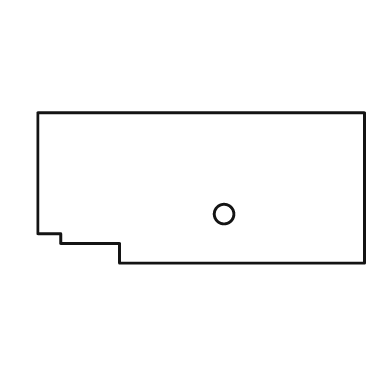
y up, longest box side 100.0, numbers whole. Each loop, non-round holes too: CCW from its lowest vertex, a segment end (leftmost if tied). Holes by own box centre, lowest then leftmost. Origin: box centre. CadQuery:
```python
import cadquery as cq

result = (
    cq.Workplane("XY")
    .moveTo(-25.0, -23.0)
    .lineTo(50.0, -23.0)
    .lineTo(50.0, 23.0)
    .lineTo(-50.0, 23.0)
    .lineTo(-50.0, -14.0)
    .lineTo(-43.0, -14.0)
    .lineTo(-43.0, -17.0)
    .lineTo(-25.0, -17.0)
    .close()
    .moveTo(7.0, -8.0)
    .circle(3.0)
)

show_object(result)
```